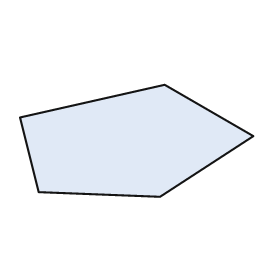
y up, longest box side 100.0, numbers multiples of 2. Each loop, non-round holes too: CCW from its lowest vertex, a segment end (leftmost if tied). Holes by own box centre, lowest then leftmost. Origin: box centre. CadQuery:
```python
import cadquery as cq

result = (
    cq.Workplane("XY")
    .moveTo(10.0, -24.0)
    .lineTo(50.0, 2.0)
    .lineTo(12.0, 24.0)
    .lineTo(-50.0, 10.0)
    .lineTo(-42.0, -22.0)
    .close()
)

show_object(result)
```